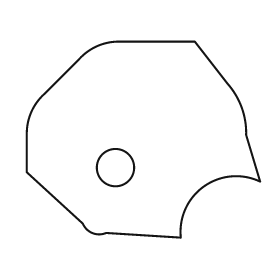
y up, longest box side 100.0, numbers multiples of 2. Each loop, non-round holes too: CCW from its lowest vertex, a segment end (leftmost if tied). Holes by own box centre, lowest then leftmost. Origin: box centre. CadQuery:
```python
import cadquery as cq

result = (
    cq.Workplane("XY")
    .moveTo(16.0, -42.0)
    .threePointArc((26.0, -20.0), (50.0, -18.0))
    .lineTo(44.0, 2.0)
    .threePointArc((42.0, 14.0), (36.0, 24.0))
    .lineTo(22.0, 42.0)
    .lineTo(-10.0, 42.0)
    .threePointArc((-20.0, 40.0), (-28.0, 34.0))
    .lineTo(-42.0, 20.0)
    .threePointArc((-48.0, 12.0), (-50.0, 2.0))
    .lineTo(-50.0, -14.0)
    .lineTo(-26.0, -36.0)
    .threePointArc((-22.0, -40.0), (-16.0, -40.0))
    .close()
    .moveTo(-12.0, -12.0)
    .circle(8.0)
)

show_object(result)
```